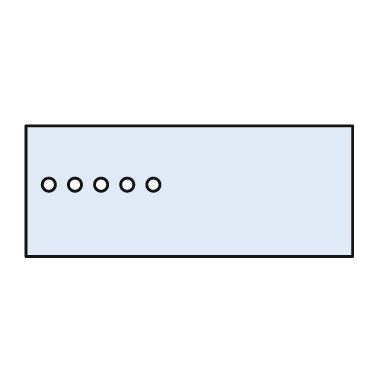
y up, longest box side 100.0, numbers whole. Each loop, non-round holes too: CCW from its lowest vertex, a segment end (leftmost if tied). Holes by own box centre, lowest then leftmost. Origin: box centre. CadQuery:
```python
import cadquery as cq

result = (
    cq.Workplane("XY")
    .moveTo(-50.0, -20.0)
    .lineTo(50.0, -20.0)
    .lineTo(50.0, 20.0)
    .lineTo(-50.0, 20.0)
    .close()
    .moveTo(-43.0, 2.0)
    .circle(2.0)
    .moveTo(-35.0, 2.0)
    .circle(2.0)
    .moveTo(-27.0, 2.0)
    .circle(2.0)
    .moveTo(-19.0, 2.0)
    .circle(2.0)
    .moveTo(-11.0, 2.0)
    .circle(2.0)
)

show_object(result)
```